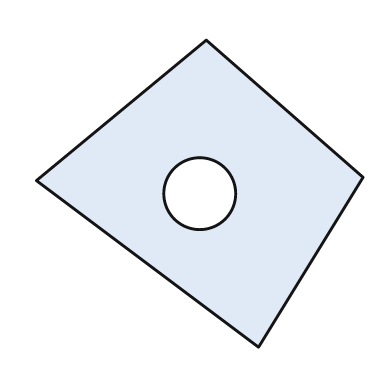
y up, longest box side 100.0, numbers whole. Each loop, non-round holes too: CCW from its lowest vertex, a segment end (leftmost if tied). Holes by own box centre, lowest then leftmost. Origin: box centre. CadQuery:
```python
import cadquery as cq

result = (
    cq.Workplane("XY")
    .moveTo(18.0, -47.0)
    .lineTo(50.0, 5.0)
    .lineTo(2.0, 47.0)
    .lineTo(-50.0, 4.0)
    .close()
    .moveTo(0.0, 0.0)
    .circle(11.0)
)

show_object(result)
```